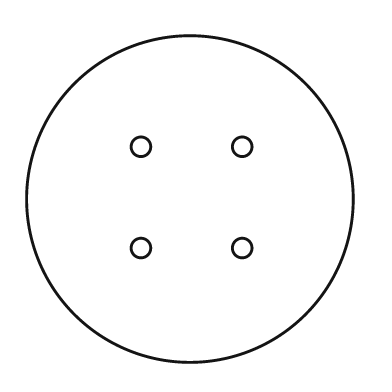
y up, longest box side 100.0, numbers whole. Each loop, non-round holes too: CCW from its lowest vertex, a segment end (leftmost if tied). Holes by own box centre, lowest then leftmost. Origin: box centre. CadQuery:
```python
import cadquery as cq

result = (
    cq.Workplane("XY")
    .moveTo(0.0, 0.0)
    .circle(50.0)
    .moveTo(-15.0, -15.0)
    .circle(3.0)
    .moveTo(16.0, -15.0)
    .circle(3.0)
    .moveTo(-15.0, 16.0)
    .circle(3.0)
    .moveTo(16.0, 16.0)
    .circle(3.0)
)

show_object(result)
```